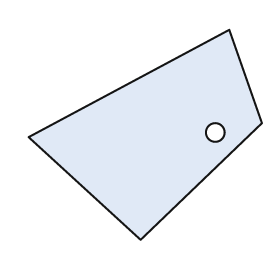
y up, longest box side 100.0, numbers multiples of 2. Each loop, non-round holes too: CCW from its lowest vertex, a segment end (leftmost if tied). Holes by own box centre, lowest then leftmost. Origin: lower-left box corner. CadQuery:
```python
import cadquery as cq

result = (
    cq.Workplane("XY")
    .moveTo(48.0, 0.0)
    .lineTo(100.0, 50.0)
    .lineTo(86.0, 90.0)
    .lineTo(0.0, 44.0)
    .close()
    .moveTo(80.0, 46.0)
    .circle(4.0)
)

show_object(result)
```